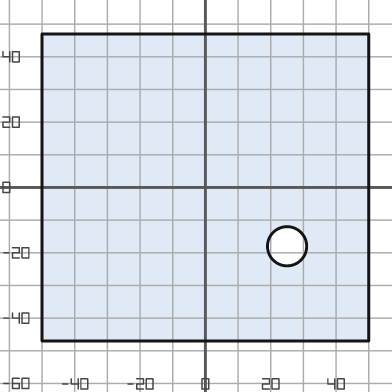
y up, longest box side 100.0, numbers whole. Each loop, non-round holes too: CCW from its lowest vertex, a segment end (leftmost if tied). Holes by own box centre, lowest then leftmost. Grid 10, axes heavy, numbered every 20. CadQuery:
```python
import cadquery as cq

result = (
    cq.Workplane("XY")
    .moveTo(-50.0, -47.0)
    .lineTo(50.0, -47.0)
    .lineTo(50.0, 47.0)
    .lineTo(-50.0, 47.0)
    .close()
    .moveTo(25.0, -18.0)
    .circle(6.0)
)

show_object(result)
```